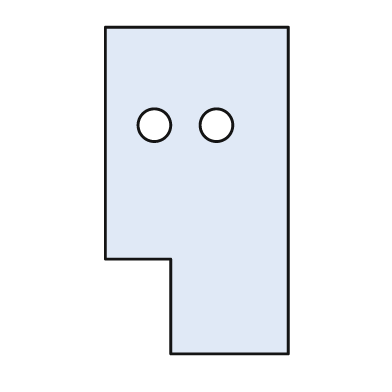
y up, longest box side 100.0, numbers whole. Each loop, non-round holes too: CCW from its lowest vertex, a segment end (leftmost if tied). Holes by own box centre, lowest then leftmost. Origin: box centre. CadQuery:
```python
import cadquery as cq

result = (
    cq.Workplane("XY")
    .moveTo(-8.0, -50.0)
    .lineTo(28.0, -50.0)
    .lineTo(28.0, 50.0)
    .lineTo(-28.0, 50.0)
    .lineTo(-28.0, -21.0)
    .lineTo(-8.0, -21.0)
    .close()
    .moveTo(-13.0, 20.0)
    .circle(5.0)
    .moveTo(6.0, 20.0)
    .circle(5.0)
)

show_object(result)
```